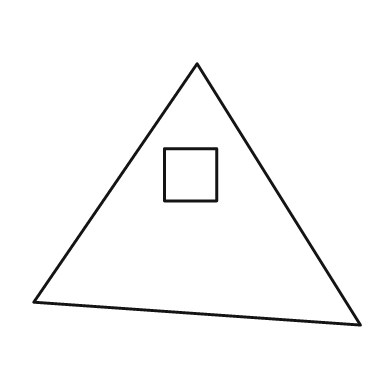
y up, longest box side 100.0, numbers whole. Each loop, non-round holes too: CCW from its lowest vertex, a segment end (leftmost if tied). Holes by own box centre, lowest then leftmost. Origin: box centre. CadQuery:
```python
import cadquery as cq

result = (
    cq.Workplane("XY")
    .moveTo(50.0, -40.0)
    .lineTo(0.0, 40.0)
    .lineTo(-50.0, -33.0)
    .close()
    .moveTo(-10.0, -2.0)
    .lineTo(6.0, -2.0)
    .lineTo(6.0, 14.0)
    .lineTo(-10.0, 14.0)
    .close()
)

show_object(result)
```